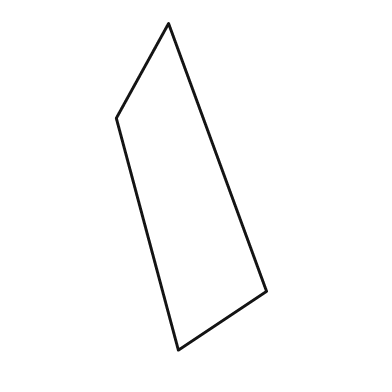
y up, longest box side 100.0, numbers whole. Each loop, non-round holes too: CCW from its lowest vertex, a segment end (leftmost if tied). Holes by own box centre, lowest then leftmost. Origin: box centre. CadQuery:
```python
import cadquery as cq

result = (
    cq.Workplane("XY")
    .moveTo(-4.0, -50.0)
    .lineTo(23.0, -32.0)
    .lineTo(-7.0, 50.0)
    .lineTo(-23.0, 21.0)
    .close()
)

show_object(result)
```